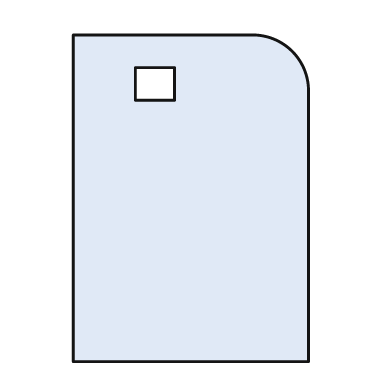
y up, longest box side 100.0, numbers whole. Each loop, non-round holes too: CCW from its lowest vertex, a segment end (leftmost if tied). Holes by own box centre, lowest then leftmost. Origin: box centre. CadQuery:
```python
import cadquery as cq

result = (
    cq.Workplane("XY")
    .moveTo(-36.0, -50.0)
    .lineTo(36.0, -50.0)
    .lineTo(36.0, 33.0)
    .threePointArc((31.0, 45.0), (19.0, 50.0))
    .lineTo(-36.0, 50.0)
    .close()
    .moveTo(-17.0, 30.0)
    .lineTo(-5.0, 30.0)
    .lineTo(-5.0, 40.0)
    .lineTo(-17.0, 40.0)
    .close()
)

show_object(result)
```